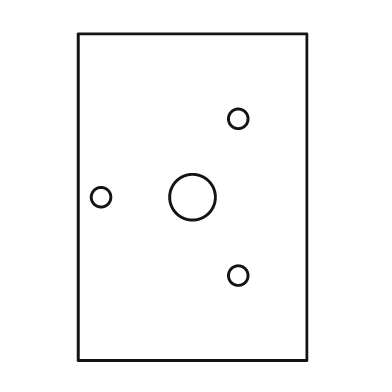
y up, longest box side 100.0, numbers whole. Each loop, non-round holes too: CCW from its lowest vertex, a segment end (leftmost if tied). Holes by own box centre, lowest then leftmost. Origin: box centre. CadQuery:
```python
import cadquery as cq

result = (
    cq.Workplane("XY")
    .moveTo(-35.0, -50.0)
    .lineTo(35.0, -50.0)
    .lineTo(35.0, 50.0)
    .lineTo(-35.0, 50.0)
    .close()
    .moveTo(14.0, -24.0)
    .circle(3.0)
    .moveTo(-28.0, 0.0)
    .circle(3.0)
    .moveTo(0.0, 0.0)
    .circle(7.0)
    .moveTo(14.0, 24.0)
    .circle(3.0)
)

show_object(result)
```